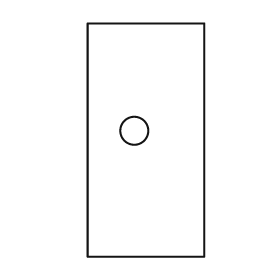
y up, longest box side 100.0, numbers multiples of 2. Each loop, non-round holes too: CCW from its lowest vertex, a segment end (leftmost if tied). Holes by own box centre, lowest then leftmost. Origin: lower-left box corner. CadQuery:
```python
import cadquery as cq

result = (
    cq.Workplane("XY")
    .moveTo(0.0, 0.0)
    .lineTo(50.0, 0.0)
    .lineTo(50.0, 100.0)
    .lineTo(0.0, 100.0)
    .close()
    .moveTo(20.0, 54.0)
    .circle(6.0)
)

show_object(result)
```